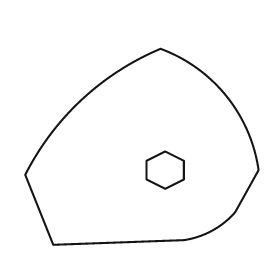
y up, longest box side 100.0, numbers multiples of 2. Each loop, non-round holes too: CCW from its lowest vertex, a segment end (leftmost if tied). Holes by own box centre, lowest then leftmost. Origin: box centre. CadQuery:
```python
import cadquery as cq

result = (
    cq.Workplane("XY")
    .moveTo(-38.0, -42.0)
    .lineTo(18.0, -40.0)
    .threePointArc((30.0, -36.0), (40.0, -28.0))
    .lineTo(50.0, -10.0)
    .threePointArc((36.0, 22.0), (8.0, 42.0))
    .threePointArc((-26.0, 20.0), (-50.0, -12.0))
    .close()
    .moveTo(10.0, -18.0)
    .lineTo(18.0, -14.0)
    .lineTo(18.0, -6.0)
    .lineTo(10.0, -2.0)
    .lineTo(2.0, -6.0)
    .lineTo(2.0, -14.0)
    .close()
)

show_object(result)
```